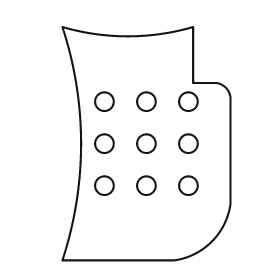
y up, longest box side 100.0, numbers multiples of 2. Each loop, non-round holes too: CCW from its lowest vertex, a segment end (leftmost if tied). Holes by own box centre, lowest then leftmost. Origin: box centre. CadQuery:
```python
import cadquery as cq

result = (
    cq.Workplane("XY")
    .moveTo(-36.0, -50.0)
    .lineTo(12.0, -50.0)
    .threePointArc((28.0, -42.0), (36.0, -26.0))
    .lineTo(36.0, 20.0)
    .threePointArc((34.0, 24.0), (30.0, 26.0))
    .lineTo(20.0, 26.0)
    .lineTo(20.0, 50.0)
    .threePointArc((-8.0, 46.0), (-36.0, 50.0))
    .threePointArc((-28.0, 0.0), (-36.0, -50.0))
    .close()
    .moveTo(-18.0, -18.0)
    .circle(4.0)
    .moveTo(0.0, -18.0)
    .circle(4.0)
    .moveTo(18.0, -18.0)
    .circle(4.0)
    .moveTo(-18.0, 0.0)
    .circle(4.0)
    .moveTo(0.0, 0.0)
    .circle(4.0)
    .moveTo(18.0, 0.0)
    .circle(4.0)
    .moveTo(-18.0, 18.0)
    .circle(4.0)
    .moveTo(0.0, 18.0)
    .circle(4.0)
    .moveTo(18.0, 18.0)
    .circle(4.0)
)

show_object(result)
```